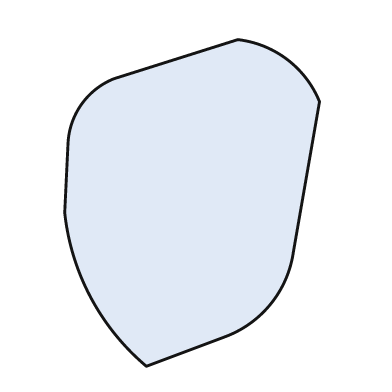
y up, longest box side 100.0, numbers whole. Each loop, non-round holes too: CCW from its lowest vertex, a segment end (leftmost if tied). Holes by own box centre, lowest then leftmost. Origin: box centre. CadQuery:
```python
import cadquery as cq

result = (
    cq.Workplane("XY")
    .moveTo(-14.0, -50.0)
    .lineTo(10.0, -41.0)
    .threePointArc((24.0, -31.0), (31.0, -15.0))
    .lineTo(39.0, 31.0)
    .threePointArc((29.0, 44.0), (14.0, 50.0))
    .lineTo(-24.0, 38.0)
    .threePointArc((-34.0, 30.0), (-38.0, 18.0))
    .lineTo(-39.0, -3.0)
    .threePointArc((-31.0, -29.0), (-14.0, -50.0))
    .close()
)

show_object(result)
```